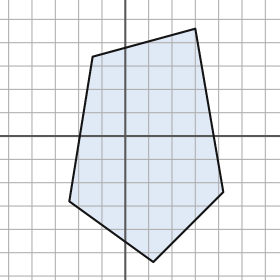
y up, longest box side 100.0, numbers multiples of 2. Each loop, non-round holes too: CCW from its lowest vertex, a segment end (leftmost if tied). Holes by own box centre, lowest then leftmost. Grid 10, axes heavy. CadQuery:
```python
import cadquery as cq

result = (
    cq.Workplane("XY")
    .moveTo(12.0, -54.0)
    .lineTo(42.0, -24.0)
    .lineTo(30.0, 46.0)
    .lineTo(-14.0, 34.0)
    .lineTo(-24.0, -28.0)
    .close()
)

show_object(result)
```